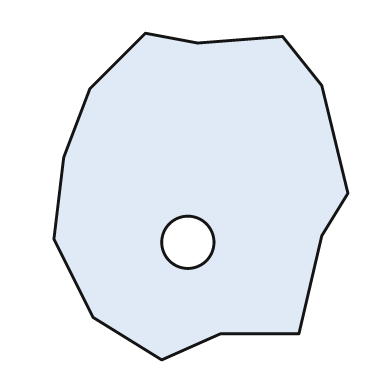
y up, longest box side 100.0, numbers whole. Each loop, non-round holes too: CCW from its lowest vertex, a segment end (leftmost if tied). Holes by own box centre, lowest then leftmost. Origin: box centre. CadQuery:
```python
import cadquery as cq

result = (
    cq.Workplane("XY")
    .moveTo(-12.0, -50.0)
    .lineTo(6.0, -42.0)
    .lineTo(30.0, -42.0)
    .lineTo(37.0, -12.0)
    .lineTo(45.0, 1.0)
    .lineTo(37.0, 34.0)
    .lineTo(25.0, 49.0)
    .lineTo(-1.0, 47.0)
    .lineTo(-17.0, 50.0)
    .lineTo(-34.0, 33.0)
    .lineTo(-42.0, 12.0)
    .lineTo(-45.0, -13.0)
    .lineTo(-33.0, -37.0)
    .close()
    .moveTo(-4.0, -14.0)
    .circle(8.0)
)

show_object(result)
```